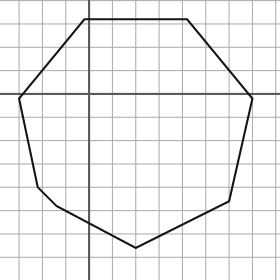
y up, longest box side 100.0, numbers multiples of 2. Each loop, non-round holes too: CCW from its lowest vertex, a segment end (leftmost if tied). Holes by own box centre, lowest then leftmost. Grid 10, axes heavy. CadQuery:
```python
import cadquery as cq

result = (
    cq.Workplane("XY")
    .moveTo(20.0, -66.0)
    .lineTo(60.0, -46.0)
    .lineTo(70.0, -2.0)
    .lineTo(42.0, 32.0)
    .lineTo(-2.0, 32.0)
    .lineTo(-30.0, -2.0)
    .lineTo(-22.0, -40.0)
    .lineTo(-14.0, -48.0)
    .close()
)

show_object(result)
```